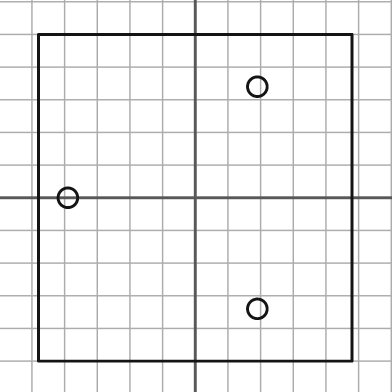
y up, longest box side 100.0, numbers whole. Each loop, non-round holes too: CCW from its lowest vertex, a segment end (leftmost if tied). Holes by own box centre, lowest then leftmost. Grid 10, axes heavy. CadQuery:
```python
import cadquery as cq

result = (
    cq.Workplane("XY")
    .moveTo(-48.0, -50.0)
    .lineTo(48.0, -50.0)
    .lineTo(48.0, 50.0)
    .lineTo(-48.0, 50.0)
    .close()
    .moveTo(19.0, -34.0)
    .circle(3.0)
    .moveTo(-39.0, 0.0)
    .circle(3.0)
    .moveTo(19.0, 34.0)
    .circle(3.0)
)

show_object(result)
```